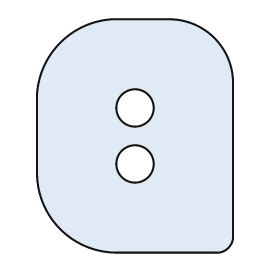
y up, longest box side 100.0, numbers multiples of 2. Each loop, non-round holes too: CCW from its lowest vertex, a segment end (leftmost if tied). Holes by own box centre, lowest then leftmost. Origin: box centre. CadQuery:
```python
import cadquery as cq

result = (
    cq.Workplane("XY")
    .moveTo(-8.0, -50.0)
    .lineTo(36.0, -50.0)
    .threePointArc((40.0, -48.0), (42.0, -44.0))
    .lineTo(42.0, 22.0)
    .threePointArc((34.0, 42.0), (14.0, 50.0))
    .lineTo(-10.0, 50.0)
    .threePointArc((-32.0, 40.0), (-42.0, 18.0))
    .lineTo(-42.0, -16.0)
    .threePointArc((-32.0, -40.0), (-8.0, -50.0))
    .close()
    .moveTo(0.0, -12.0)
    .circle(8.0)
    .moveTo(0.0, 12.0)
    .circle(8.0)
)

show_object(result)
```